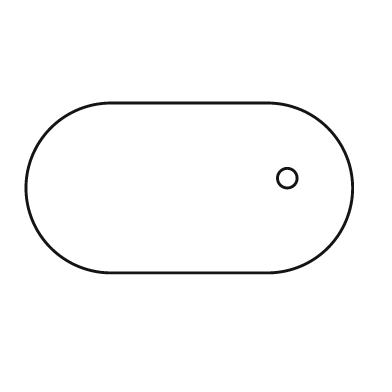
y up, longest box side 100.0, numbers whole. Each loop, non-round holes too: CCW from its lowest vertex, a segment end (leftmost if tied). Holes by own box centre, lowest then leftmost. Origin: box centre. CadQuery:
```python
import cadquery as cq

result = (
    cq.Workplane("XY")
    .moveTo(-24.0, -26.0)
    .lineTo(24.0, -26.0)
    .threePointArc((50.0, 0.0), (24.0, 26.0))
    .lineTo(-24.0, 26.0)
    .threePointArc((-50.0, 0.0), (-24.0, -26.0))
    .close()
    .moveTo(30.0, 3.0)
    .circle(3.0)
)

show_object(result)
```